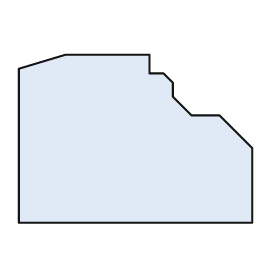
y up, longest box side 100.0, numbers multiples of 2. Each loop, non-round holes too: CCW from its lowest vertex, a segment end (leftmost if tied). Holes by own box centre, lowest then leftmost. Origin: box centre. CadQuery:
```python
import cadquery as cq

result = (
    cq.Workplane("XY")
    .moveTo(-50.0, -36.0)
    .lineTo(50.0, -36.0)
    .lineTo(50.0, -4.0)
    .lineTo(36.0, 10.0)
    .lineTo(24.0, 10.0)
    .lineTo(16.0, 18.0)
    .lineTo(16.0, 24.0)
    .lineTo(12.0, 28.0)
    .lineTo(6.0, 28.0)
    .lineTo(6.0, 36.0)
    .lineTo(-30.0, 36.0)
    .lineTo(-50.0, 30.0)
    .close()
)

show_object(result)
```